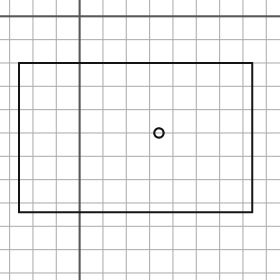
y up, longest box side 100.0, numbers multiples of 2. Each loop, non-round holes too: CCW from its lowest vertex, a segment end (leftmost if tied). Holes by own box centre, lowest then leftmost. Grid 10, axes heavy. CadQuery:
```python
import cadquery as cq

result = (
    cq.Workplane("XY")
    .moveTo(-26.0, -84.0)
    .lineTo(74.0, -84.0)
    .lineTo(74.0, -20.0)
    .lineTo(-26.0, -20.0)
    .close()
    .moveTo(34.0, -50.0)
    .circle(2.0)
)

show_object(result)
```